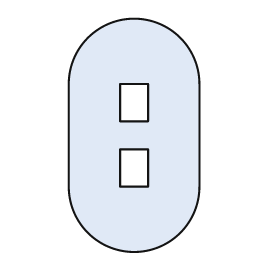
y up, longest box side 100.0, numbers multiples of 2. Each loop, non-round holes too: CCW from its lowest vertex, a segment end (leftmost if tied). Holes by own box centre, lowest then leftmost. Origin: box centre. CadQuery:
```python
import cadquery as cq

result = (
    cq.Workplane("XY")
    .moveTo(-28.0, -22.0)
    .threePointArc((0.0, -50.0), (28.0, -22.0))
    .lineTo(28.0, 22.0)
    .threePointArc((0.0, 50.0), (-28.0, 22.0))
    .close()
    .moveTo(-6.0, -22.0)
    .lineTo(6.0, -22.0)
    .lineTo(6.0, -6.0)
    .lineTo(-6.0, -6.0)
    .close()
    .moveTo(-6.0, 6.0)
    .lineTo(6.0, 6.0)
    .lineTo(6.0, 22.0)
    .lineTo(-6.0, 22.0)
    .close()
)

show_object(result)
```